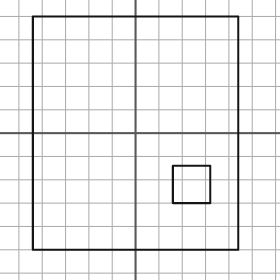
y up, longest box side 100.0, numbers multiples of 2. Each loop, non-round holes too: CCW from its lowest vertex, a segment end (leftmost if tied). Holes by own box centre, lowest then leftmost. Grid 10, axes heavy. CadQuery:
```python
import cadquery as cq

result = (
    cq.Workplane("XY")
    .moveTo(-44.0, -50.0)
    .lineTo(44.0, -50.0)
    .lineTo(44.0, 50.0)
    .lineTo(-44.0, 50.0)
    .close()
    .moveTo(16.0, -30.0)
    .lineTo(32.0, -30.0)
    .lineTo(32.0, -14.0)
    .lineTo(16.0, -14.0)
    .close()
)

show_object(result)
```